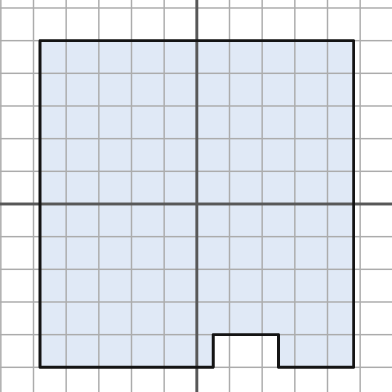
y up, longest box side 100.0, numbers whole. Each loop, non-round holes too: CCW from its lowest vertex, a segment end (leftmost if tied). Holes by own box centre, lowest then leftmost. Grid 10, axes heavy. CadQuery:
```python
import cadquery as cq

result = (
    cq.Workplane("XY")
    .moveTo(-48.0, -50.0)
    .lineTo(5.0, -50.0)
    .lineTo(5.0, -40.0)
    .lineTo(25.0, -40.0)
    .lineTo(25.0, -50.0)
    .lineTo(48.0, -50.0)
    .lineTo(48.0, 50.0)
    .lineTo(-48.0, 50.0)
    .close()
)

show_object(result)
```